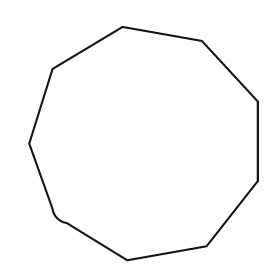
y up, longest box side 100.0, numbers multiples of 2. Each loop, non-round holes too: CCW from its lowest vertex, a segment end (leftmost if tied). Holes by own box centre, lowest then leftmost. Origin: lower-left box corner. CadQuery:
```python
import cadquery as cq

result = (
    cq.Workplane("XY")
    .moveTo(42.0, 0.0)
    .lineTo(76.0, 6.0)
    .lineTo(98.0, 34.0)
    .lineTo(98.0, 68.0)
    .lineTo(74.0, 94.0)
    .lineTo(40.0, 100.0)
    .lineTo(10.0, 82.0)
    .lineTo(0.0, 50.0)
    .lineTo(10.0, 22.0)
    .threePointArc((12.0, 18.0), (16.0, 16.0))
    .close()
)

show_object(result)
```